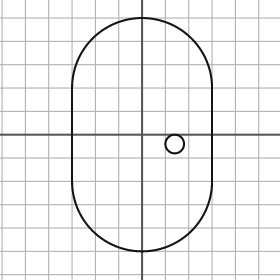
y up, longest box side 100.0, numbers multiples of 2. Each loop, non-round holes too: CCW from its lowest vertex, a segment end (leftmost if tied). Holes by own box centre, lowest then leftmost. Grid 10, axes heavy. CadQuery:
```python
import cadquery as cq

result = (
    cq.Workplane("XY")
    .moveTo(-30.0, -20.0)
    .threePointArc((0.0, -50.0), (30.0, -20.0))
    .lineTo(30.0, 20.0)
    .threePointArc((0.0, 50.0), (-30.0, 20.0))
    .close()
    .moveTo(14.0, -4.0)
    .circle(4.0)
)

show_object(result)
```